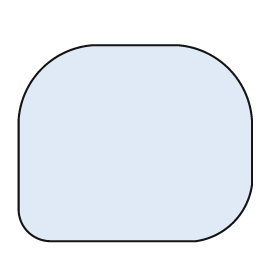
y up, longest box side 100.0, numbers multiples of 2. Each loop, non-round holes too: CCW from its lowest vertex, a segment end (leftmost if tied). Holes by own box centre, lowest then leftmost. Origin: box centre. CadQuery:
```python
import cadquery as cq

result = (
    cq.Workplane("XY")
    .moveTo(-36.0, -42.0)
    .lineTo(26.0, -42.0)
    .threePointArc((42.0, -34.0), (50.0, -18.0))
    .lineTo(50.0, 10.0)
    .threePointArc((40.0, 32.0), (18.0, 42.0))
    .lineTo(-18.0, 42.0)
    .threePointArc((-40.0, 32.0), (-50.0, 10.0))
    .lineTo(-50.0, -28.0)
    .threePointArc((-46.0, -38.0), (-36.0, -42.0))
    .close()
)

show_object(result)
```